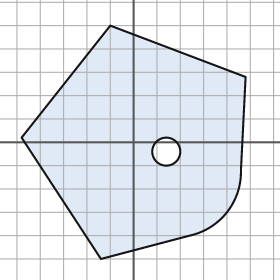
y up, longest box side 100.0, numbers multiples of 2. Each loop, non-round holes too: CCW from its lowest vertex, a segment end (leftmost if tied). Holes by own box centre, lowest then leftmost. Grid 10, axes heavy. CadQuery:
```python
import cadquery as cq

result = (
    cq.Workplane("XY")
    .moveTo(-14.0, -50.0)
    .lineTo(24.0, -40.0)
    .threePointArc((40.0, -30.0), (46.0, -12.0))
    .lineTo(48.0, 28.0)
    .lineTo(-10.0, 50.0)
    .lineTo(-48.0, 2.0)
    .close()
    .moveTo(14.0, -4.0)
    .circle(6.0)
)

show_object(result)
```